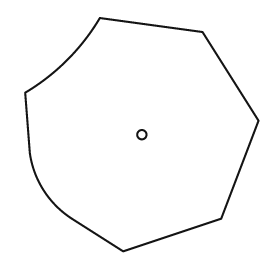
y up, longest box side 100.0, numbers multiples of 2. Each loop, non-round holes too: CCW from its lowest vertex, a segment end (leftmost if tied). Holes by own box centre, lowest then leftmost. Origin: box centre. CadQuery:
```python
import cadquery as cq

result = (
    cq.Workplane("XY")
    .moveTo(-8.0, -50.0)
    .lineTo(34.0, -36.0)
    .lineTo(50.0, 6.0)
    .lineTo(26.0, 44.0)
    .lineTo(-18.0, 50.0)
    .threePointArc((-32.0, 32.0), (-50.0, 18.0))
    .lineTo(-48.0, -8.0)
    .threePointArc((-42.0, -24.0), (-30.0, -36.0))
    .close()
    .moveTo(0.0, 0.0)
    .circle(2.0)
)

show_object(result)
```